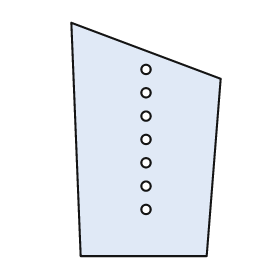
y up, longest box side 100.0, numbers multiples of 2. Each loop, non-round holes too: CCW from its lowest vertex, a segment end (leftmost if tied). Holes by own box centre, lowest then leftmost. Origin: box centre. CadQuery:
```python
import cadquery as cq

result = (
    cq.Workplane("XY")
    .moveTo(-28.0, -50.0)
    .lineTo(26.0, -50.0)
    .lineTo(32.0, 26.0)
    .lineTo(-32.0, 50.0)
    .close()
    .moveTo(0.0, -30.0)
    .circle(2.0)
    .moveTo(0.0, -20.0)
    .circle(2.0)
    .moveTo(0.0, -10.0)
    .circle(2.0)
    .moveTo(0.0, 0.0)
    .circle(2.0)
    .moveTo(0.0, 10.0)
    .circle(2.0)
    .moveTo(0.0, 20.0)
    .circle(2.0)
    .moveTo(0.0, 30.0)
    .circle(2.0)
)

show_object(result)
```